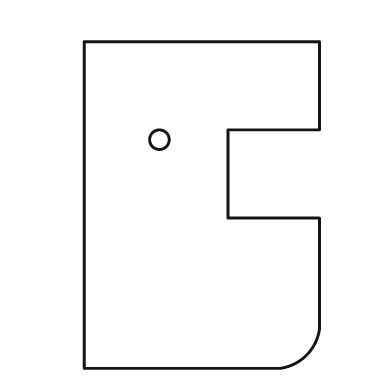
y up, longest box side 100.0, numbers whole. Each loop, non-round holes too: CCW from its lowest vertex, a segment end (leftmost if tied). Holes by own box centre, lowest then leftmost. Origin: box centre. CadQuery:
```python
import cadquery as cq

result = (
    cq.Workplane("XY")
    .moveTo(-36.0, -50.0)
    .lineTo(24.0, -50.0)
    .threePointArc((32.0, -46.0), (36.0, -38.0))
    .lineTo(36.0, -4.0)
    .lineTo(8.0, -4.0)
    .lineTo(8.0, 23.0)
    .lineTo(36.0, 23.0)
    .lineTo(36.0, 50.0)
    .lineTo(-36.0, 50.0)
    .close()
    .moveTo(-13.0, 20.0)
    .circle(3.0)
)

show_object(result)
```